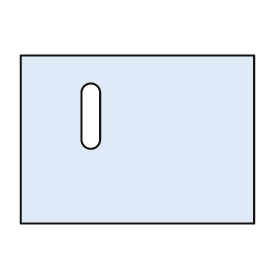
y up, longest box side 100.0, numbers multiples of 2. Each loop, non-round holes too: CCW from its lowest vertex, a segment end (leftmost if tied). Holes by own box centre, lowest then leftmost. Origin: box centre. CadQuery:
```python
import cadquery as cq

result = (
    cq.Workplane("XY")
    .moveTo(-50.0, -36.0)
    .lineTo(50.0, -36.0)
    .lineTo(50.0, 36.0)
    .lineTo(-50.0, 36.0)
    .close()
    .moveTo(-24.0, 0.0)
    .threePointArc((-20.0, -4.0), (-16.0, 0.0))
    .lineTo(-16.0, 20.0)
    .threePointArc((-20.0, 24.0), (-24.0, 20.0))
    .close()
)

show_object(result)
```